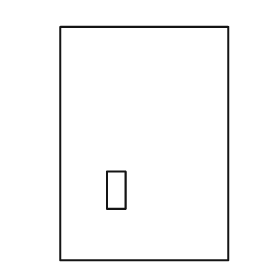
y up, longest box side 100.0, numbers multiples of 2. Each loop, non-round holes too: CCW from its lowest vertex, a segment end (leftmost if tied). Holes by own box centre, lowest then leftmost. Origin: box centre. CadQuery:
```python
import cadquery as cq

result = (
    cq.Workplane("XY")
    .moveTo(-36.0, -50.0)
    .lineTo(36.0, -50.0)
    .lineTo(36.0, 50.0)
    .lineTo(-36.0, 50.0)
    .close()
    .moveTo(-16.0, -28.0)
    .lineTo(-8.0, -28.0)
    .lineTo(-8.0, -12.0)
    .lineTo(-16.0, -12.0)
    .close()
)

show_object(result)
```